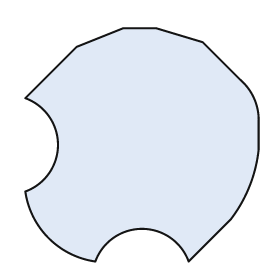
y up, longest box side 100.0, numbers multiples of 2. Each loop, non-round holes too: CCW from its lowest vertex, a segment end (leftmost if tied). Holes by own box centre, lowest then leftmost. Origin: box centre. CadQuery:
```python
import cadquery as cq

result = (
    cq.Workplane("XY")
    .moveTo(-20.0, -50.0)
    .threePointArc((0.0, -36.0), (20.0, -50.0))
    .lineTo(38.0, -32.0)
    .threePointArc((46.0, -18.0), (50.0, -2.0))
    .lineTo(50.0, 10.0)
    .threePointArc((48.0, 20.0), (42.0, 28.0))
    .lineTo(26.0, 44.0)
    .lineTo(6.0, 50.0)
    .lineTo(-8.0, 50.0)
    .lineTo(-28.0, 42.0)
    .lineTo(-50.0, 20.0)
    .threePointArc((-36.0, 0.0), (-50.0, -20.0))
    .threePointArc((-40.0, -40.0), (-20.0, -50.0))
    .close()
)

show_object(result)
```